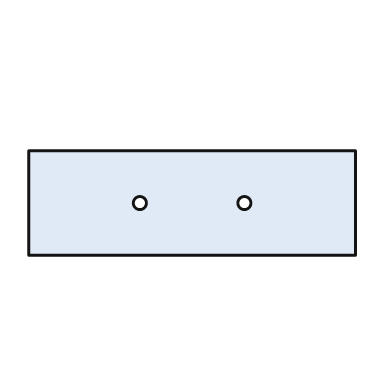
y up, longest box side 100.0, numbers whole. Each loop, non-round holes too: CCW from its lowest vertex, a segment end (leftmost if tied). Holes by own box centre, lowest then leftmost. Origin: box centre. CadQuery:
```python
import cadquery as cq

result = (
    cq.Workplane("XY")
    .moveTo(-50.0, -16.0)
    .lineTo(50.0, -16.0)
    .lineTo(50.0, 16.0)
    .lineTo(-50.0, 16.0)
    .close()
    .moveTo(-16.0, 0.0)
    .circle(2.0)
    .moveTo(16.0, 0.0)
    .circle(2.0)
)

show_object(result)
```